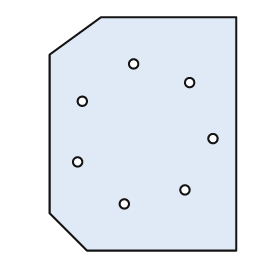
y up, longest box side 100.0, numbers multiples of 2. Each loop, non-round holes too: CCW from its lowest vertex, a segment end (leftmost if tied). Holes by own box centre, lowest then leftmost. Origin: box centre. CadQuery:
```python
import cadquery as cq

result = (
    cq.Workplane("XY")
    .moveTo(-24.0, -50.0)
    .lineTo(40.0, -50.0)
    .lineTo(40.0, 50.0)
    .lineTo(-18.0, 50.0)
    .lineTo(-40.0, 34.0)
    .lineTo(-40.0, -34.0)
    .close()
    .moveTo(-8.0, -30.0)
    .circle(2.0)
    .moveTo(18.0, -24.0)
    .circle(2.0)
    .moveTo(-28.0, -12.0)
    .circle(2.0)
    .moveTo(30.0, -2.0)
    .circle(2.0)
    .moveTo(-26.0, 14.0)
    .circle(2.0)
    .moveTo(20.0, 22.0)
    .circle(2.0)
    .moveTo(-4.0, 30.0)
    .circle(2.0)
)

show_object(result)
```